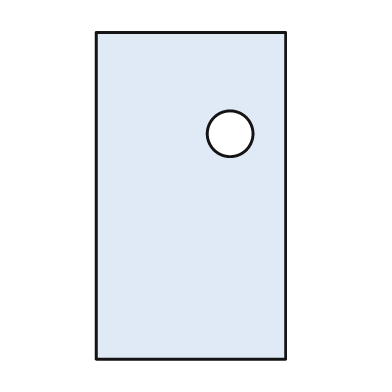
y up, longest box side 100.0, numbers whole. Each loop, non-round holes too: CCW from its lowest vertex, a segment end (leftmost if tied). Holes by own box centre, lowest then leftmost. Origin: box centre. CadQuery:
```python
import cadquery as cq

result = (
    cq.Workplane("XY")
    .moveTo(-29.0, -50.0)
    .lineTo(29.0, -50.0)
    .lineTo(29.0, 50.0)
    .lineTo(-29.0, 50.0)
    .close()
    .moveTo(12.0, 19.0)
    .circle(7.0)
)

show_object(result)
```